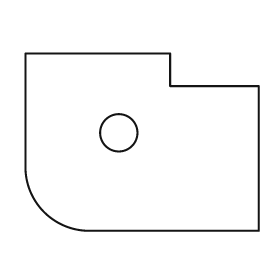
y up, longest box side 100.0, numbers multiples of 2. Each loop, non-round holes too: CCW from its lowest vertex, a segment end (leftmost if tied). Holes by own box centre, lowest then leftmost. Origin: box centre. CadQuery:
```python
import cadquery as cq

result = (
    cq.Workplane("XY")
    .moveTo(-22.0, -38.0)
    .lineTo(50.0, -38.0)
    .lineTo(50.0, 24.0)
    .lineTo(12.0, 24.0)
    .lineTo(12.0, 38.0)
    .lineTo(-50.0, 38.0)
    .lineTo(-50.0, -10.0)
    .threePointArc((-42.0, -30.0), (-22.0, -38.0))
    .close()
    .moveTo(-10.0, 4.0)
    .circle(8.0)
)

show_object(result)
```